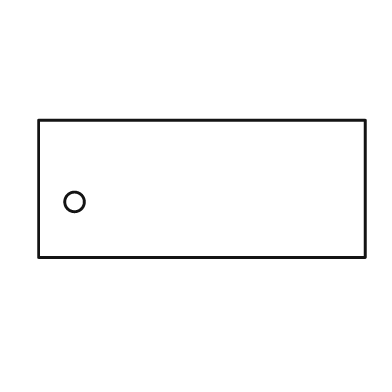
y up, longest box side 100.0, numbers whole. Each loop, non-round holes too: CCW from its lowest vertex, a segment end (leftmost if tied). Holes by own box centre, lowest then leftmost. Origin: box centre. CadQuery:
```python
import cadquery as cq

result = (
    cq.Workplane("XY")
    .moveTo(-50.0, -21.0)
    .lineTo(50.0, -21.0)
    .lineTo(50.0, 21.0)
    .lineTo(-50.0, 21.0)
    .close()
    .moveTo(-39.0, -4.0)
    .circle(3.0)
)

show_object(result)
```